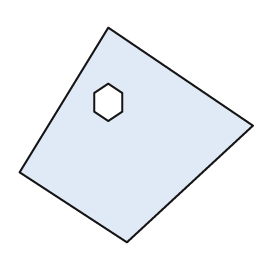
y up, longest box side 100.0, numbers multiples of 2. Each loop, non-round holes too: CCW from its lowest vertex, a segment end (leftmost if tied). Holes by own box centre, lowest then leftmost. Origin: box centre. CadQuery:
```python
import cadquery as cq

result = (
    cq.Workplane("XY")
    .moveTo(-4.0, -46.0)
    .lineTo(50.0, 4.0)
    .lineTo(-12.0, 46.0)
    .lineTo(-50.0, -16.0)
    .close()
    .moveTo(-12.0, 6.0)
    .lineTo(-6.0, 10.0)
    .lineTo(-6.0, 18.0)
    .lineTo(-12.0, 22.0)
    .lineTo(-18.0, 18.0)
    .lineTo(-18.0, 10.0)
    .close()
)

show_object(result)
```